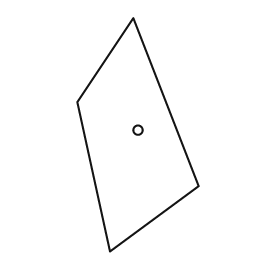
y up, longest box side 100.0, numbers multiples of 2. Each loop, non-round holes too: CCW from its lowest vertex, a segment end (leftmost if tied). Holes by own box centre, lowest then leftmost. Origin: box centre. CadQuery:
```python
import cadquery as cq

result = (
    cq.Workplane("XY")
    .moveTo(-12.0, -50.0)
    .lineTo(26.0, -22.0)
    .lineTo(-2.0, 50.0)
    .lineTo(-26.0, 14.0)
    .close()
    .moveTo(0.0, 2.0)
    .circle(2.0)
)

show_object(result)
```